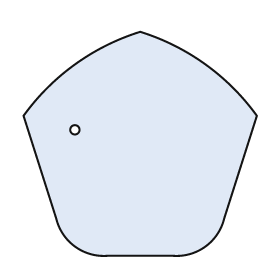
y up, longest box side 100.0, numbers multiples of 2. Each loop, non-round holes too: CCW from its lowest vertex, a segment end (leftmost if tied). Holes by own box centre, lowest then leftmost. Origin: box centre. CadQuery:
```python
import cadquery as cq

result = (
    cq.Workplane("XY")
    .moveTo(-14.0, -48.0)
    .lineTo(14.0, -48.0)
    .threePointArc((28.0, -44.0), (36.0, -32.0))
    .lineTo(50.0, 12.0)
    .threePointArc((28.0, 34.0), (0.0, 48.0))
    .threePointArc((-28.0, 34.0), (-50.0, 12.0))
    .lineTo(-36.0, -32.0)
    .threePointArc((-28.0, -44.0), (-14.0, -48.0))
    .close()
    .moveTo(-28.0, 6.0)
    .circle(2.0)
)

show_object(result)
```